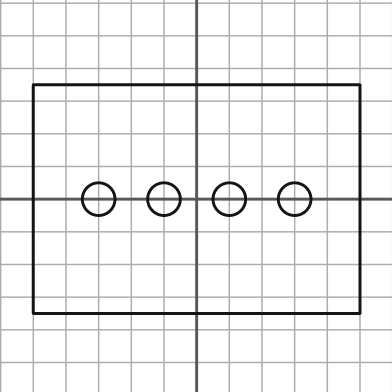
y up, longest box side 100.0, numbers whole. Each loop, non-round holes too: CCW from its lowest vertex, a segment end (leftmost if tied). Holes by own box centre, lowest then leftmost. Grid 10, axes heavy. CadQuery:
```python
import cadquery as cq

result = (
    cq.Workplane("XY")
    .moveTo(-50.0, -35.0)
    .lineTo(50.0, -35.0)
    .lineTo(50.0, 35.0)
    .lineTo(-50.0, 35.0)
    .close()
    .moveTo(-30.0, 0.0)
    .circle(5.0)
    .moveTo(-10.0, 0.0)
    .circle(5.0)
    .moveTo(10.0, 0.0)
    .circle(5.0)
    .moveTo(30.0, 0.0)
    .circle(5.0)
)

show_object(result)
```